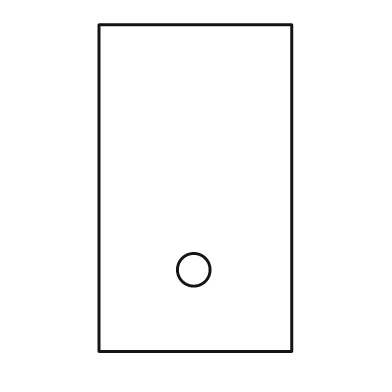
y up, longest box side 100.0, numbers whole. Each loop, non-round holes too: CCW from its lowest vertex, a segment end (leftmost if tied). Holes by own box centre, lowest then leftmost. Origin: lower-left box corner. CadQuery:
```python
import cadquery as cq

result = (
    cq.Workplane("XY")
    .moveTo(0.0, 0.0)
    .lineTo(59.0, 0.0)
    .lineTo(59.0, 100.0)
    .lineTo(0.0, 100.0)
    .close()
    .moveTo(29.0, 25.0)
    .circle(5.0)
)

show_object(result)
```